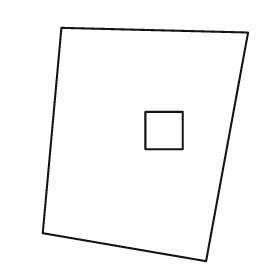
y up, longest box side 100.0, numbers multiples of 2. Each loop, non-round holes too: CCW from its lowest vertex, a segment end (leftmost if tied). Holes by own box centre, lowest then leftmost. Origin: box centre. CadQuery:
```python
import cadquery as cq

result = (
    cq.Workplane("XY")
    .moveTo(26.0, -50.0)
    .lineTo(44.0, 48.0)
    .lineTo(-36.0, 50.0)
    .lineTo(-44.0, -38.0)
    .close()
    .moveTo(0.0, -2.0)
    .lineTo(16.0, -2.0)
    .lineTo(16.0, 14.0)
    .lineTo(0.0, 14.0)
    .close()
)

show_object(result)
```